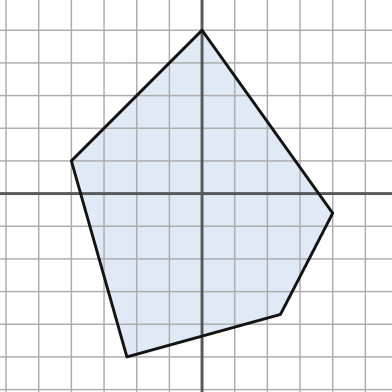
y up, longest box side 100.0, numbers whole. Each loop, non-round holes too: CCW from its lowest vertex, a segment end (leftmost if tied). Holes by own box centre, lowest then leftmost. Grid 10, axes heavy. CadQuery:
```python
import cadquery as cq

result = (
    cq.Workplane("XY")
    .moveTo(-23.0, -50.0)
    .lineTo(24.0, -37.0)
    .lineTo(40.0, -6.0)
    .lineTo(0.0, 50.0)
    .lineTo(-40.0, 10.0)
    .close()
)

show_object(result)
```